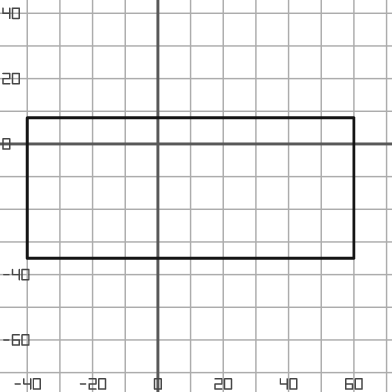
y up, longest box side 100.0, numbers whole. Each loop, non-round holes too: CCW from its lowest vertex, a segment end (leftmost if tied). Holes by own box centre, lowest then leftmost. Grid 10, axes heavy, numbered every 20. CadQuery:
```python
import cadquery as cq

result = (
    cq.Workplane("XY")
    .moveTo(-40.0, -35.0)
    .lineTo(60.0, -35.0)
    .lineTo(60.0, 8.0)
    .lineTo(-40.0, 8.0)
    .close()
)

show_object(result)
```